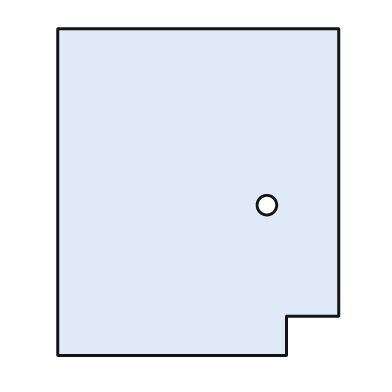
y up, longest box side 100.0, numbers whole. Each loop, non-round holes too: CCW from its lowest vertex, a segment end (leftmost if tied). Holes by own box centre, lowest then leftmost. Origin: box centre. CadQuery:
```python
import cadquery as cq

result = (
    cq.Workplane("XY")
    .moveTo(-43.0, -50.0)
    .lineTo(27.0, -50.0)
    .lineTo(27.0, -38.0)
    .lineTo(43.0, -38.0)
    .lineTo(43.0, 50.0)
    .lineTo(-43.0, 50.0)
    .close()
    .moveTo(21.0, -4.0)
    .circle(3.0)
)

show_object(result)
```